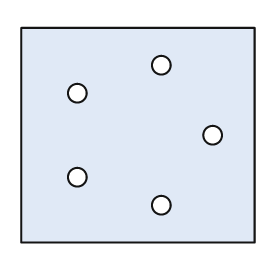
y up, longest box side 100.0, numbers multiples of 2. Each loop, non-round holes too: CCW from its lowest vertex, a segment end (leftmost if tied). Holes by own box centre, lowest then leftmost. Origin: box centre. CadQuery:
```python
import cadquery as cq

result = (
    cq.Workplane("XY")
    .moveTo(-50.0, -46.0)
    .lineTo(50.0, -46.0)
    .lineTo(50.0, 46.0)
    .lineTo(-50.0, 46.0)
    .close()
    .moveTo(10.0, -30.0)
    .circle(4.0)
    .moveTo(-26.0, -18.0)
    .circle(4.0)
    .moveTo(32.0, 0.0)
    .circle(4.0)
    .moveTo(-26.0, 18.0)
    .circle(4.0)
    .moveTo(10.0, 30.0)
    .circle(4.0)
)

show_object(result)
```